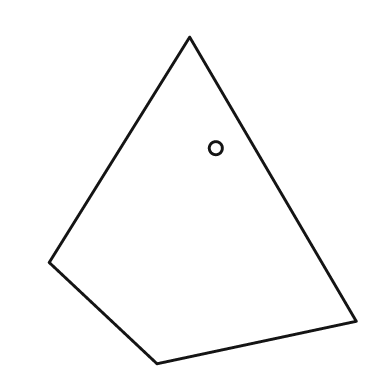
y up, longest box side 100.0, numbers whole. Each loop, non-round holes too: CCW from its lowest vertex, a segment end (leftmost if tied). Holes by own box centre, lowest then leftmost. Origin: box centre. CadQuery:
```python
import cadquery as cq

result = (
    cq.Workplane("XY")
    .moveTo(-14.0, -50.0)
    .lineTo(47.0, -37.0)
    .lineTo(-4.0, 50.0)
    .lineTo(-47.0, -19.0)
    .close()
    .moveTo(4.0, 16.0)
    .circle(2.0)
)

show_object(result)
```